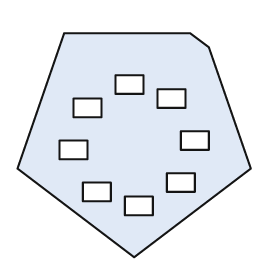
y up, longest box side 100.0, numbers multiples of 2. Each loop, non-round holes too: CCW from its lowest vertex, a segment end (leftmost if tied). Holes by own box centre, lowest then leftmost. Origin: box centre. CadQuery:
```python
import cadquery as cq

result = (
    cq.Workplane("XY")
    .moveTo(0.0, -48.0)
    .lineTo(50.0, -10.0)
    .lineTo(32.0, 42.0)
    .lineTo(24.0, 48.0)
    .lineTo(-30.0, 48.0)
    .lineTo(-50.0, -10.0)
    .close()
    .moveTo(-4.0, -30.0)
    .lineTo(8.0, -30.0)
    .lineTo(8.0, -22.0)
    .lineTo(-4.0, -22.0)
    .close()
    .moveTo(-22.0, -24.0)
    .lineTo(-10.0, -24.0)
    .lineTo(-10.0, -16.0)
    .lineTo(-22.0, -16.0)
    .close()
    .moveTo(14.0, -20.0)
    .lineTo(26.0, -20.0)
    .lineTo(26.0, -12.0)
    .lineTo(14.0, -12.0)
    .close()
    .moveTo(-32.0, -6.0)
    .lineTo(-20.0, -6.0)
    .lineTo(-20.0, 2.0)
    .lineTo(-32.0, 2.0)
    .close()
    .moveTo(20.0, -2.0)
    .lineTo(32.0, -2.0)
    .lineTo(32.0, 6.0)
    .lineTo(20.0, 6.0)
    .close()
    .moveTo(-26.0, 12.0)
    .lineTo(-14.0, 12.0)
    .lineTo(-14.0, 20.0)
    .lineTo(-26.0, 20.0)
    .close()
    .moveTo(10.0, 16.0)
    .lineTo(22.0, 16.0)
    .lineTo(22.0, 24.0)
    .lineTo(10.0, 24.0)
    .close()
    .moveTo(-8.0, 22.0)
    .lineTo(4.0, 22.0)
    .lineTo(4.0, 30.0)
    .lineTo(-8.0, 30.0)
    .close()
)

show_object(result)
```